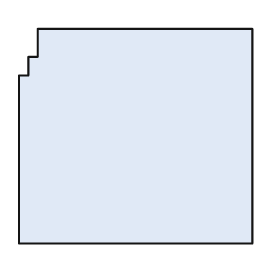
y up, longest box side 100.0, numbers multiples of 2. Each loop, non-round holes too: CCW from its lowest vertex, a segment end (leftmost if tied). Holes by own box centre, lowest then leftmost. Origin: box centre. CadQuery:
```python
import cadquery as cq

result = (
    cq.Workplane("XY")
    .moveTo(-50.0, -46.0)
    .lineTo(50.0, -46.0)
    .lineTo(50.0, 46.0)
    .lineTo(-42.0, 46.0)
    .lineTo(-42.0, 34.0)
    .lineTo(-46.0, 34.0)
    .lineTo(-46.0, 26.0)
    .lineTo(-50.0, 26.0)
    .close()
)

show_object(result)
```